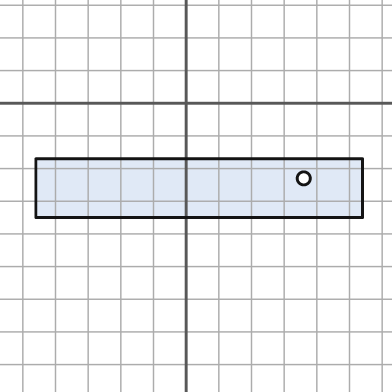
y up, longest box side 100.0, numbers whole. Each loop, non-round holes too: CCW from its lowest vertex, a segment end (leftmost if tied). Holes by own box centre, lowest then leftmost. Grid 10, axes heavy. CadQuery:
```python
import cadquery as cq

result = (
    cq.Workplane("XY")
    .moveTo(-46.0, -35.0)
    .lineTo(54.0, -35.0)
    .lineTo(54.0, -17.0)
    .lineTo(-46.0, -17.0)
    .close()
    .moveTo(36.0, -23.0)
    .circle(2.0)
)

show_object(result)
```